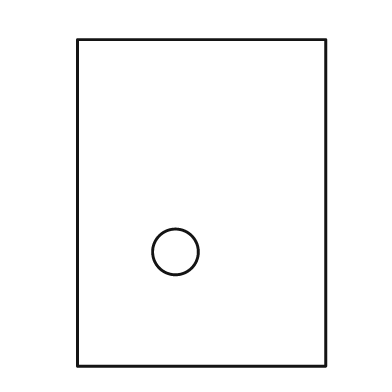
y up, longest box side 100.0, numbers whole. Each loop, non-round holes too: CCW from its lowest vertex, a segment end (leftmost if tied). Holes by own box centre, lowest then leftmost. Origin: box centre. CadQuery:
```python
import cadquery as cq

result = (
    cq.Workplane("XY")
    .moveTo(-38.0, -50.0)
    .lineTo(38.0, -50.0)
    .lineTo(38.0, 50.0)
    .lineTo(-38.0, 50.0)
    .close()
    .moveTo(-8.0, -15.0)
    .circle(7.0)
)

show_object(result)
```